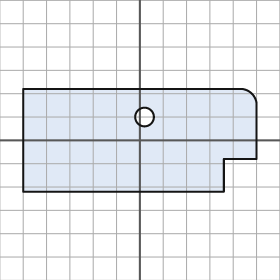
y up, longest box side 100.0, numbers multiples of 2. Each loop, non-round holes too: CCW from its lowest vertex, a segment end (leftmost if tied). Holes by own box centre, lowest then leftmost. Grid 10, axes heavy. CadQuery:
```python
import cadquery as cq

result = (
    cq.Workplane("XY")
    .moveTo(-50.0, -22.0)
    .lineTo(36.0, -22.0)
    .lineTo(36.0, -8.0)
    .lineTo(50.0, -8.0)
    .lineTo(50.0, 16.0)
    .threePointArc((48.0, 20.0), (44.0, 22.0))
    .lineTo(-50.0, 22.0)
    .close()
    .moveTo(2.0, 10.0)
    .circle(4.0)
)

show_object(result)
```